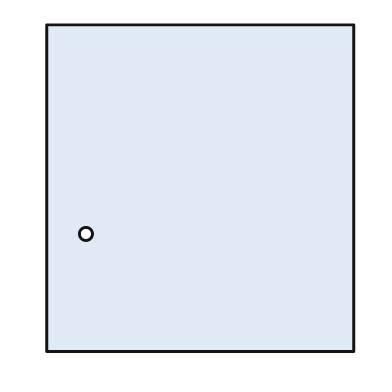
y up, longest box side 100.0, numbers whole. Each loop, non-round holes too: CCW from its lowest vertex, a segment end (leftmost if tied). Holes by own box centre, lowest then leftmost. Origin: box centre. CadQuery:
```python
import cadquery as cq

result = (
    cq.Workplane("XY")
    .moveTo(-47.0, -50.0)
    .lineTo(47.0, -50.0)
    .lineTo(47.0, 50.0)
    .lineTo(-47.0, 50.0)
    .close()
    .moveTo(-35.0, -14.0)
    .circle(2.0)
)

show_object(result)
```